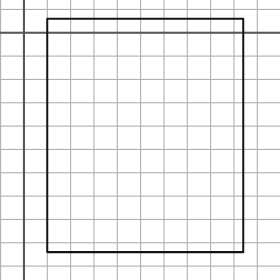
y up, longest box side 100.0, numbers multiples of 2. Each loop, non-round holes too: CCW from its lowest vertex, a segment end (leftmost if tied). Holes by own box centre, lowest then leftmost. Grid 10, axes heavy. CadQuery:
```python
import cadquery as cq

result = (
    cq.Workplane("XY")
    .moveTo(10.0, -94.0)
    .lineTo(94.0, -94.0)
    .lineTo(94.0, 6.0)
    .lineTo(10.0, 6.0)
    .close()
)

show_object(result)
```